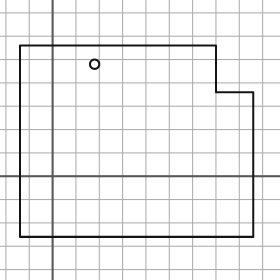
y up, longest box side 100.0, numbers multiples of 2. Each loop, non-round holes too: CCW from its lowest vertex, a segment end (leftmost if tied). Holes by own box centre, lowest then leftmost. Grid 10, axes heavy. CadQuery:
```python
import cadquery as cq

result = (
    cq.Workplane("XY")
    .moveTo(-14.0, -26.0)
    .lineTo(86.0, -26.0)
    .lineTo(86.0, 36.0)
    .lineTo(70.0, 36.0)
    .lineTo(70.0, 56.0)
    .lineTo(-14.0, 56.0)
    .close()
    .moveTo(18.0, 48.0)
    .circle(2.0)
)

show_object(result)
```